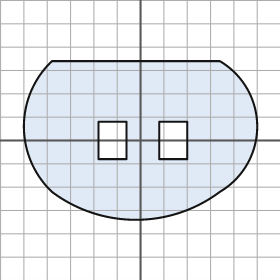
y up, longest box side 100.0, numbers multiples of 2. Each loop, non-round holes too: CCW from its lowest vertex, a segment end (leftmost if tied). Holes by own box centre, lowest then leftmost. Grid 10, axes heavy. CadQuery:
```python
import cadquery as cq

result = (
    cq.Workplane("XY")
    .moveTo(-38.0, -22.0)
    .threePointArc((-2.0, -34.0), (34.0, -22.0))
    .threePointArc((50.0, 6.0), (34.0, 34.0))
    .lineTo(-38.0, 34.0)
    .threePointArc((-50.0, 6.0), (-38.0, -22.0))
    .close()
    .moveTo(-18.0, -8.0)
    .lineTo(-6.0, -8.0)
    .lineTo(-6.0, 8.0)
    .lineTo(-18.0, 8.0)
    .close()
    .moveTo(8.0, -8.0)
    .lineTo(20.0, -8.0)
    .lineTo(20.0, 8.0)
    .lineTo(8.0, 8.0)
    .close()
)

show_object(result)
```